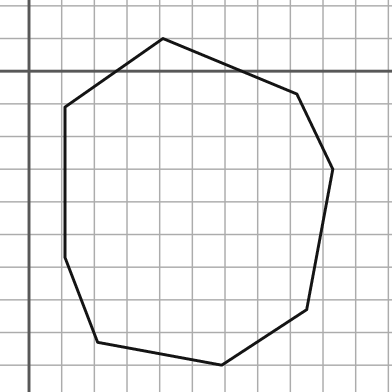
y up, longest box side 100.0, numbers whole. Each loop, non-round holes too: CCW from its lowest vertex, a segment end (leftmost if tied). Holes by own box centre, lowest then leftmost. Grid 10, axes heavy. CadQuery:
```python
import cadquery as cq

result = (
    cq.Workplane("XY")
    .moveTo(59.0, -90.0)
    .lineTo(85.0, -73.0)
    .lineTo(93.0, -30.0)
    .lineTo(82.0, -7.0)
    .lineTo(41.0, 10.0)
    .lineTo(11.0, -11.0)
    .lineTo(11.0, -57.0)
    .lineTo(21.0, -83.0)
    .close()
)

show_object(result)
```